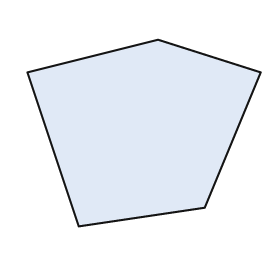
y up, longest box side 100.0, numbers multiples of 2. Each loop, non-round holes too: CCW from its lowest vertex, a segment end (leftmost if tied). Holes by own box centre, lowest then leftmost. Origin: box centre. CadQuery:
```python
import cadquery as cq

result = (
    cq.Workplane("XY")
    .moveTo(-28.0, -40.0)
    .lineTo(26.0, -32.0)
    .lineTo(50.0, 26.0)
    .lineTo(6.0, 40.0)
    .lineTo(-50.0, 26.0)
    .close()
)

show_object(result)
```